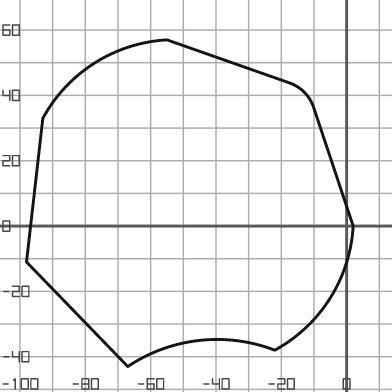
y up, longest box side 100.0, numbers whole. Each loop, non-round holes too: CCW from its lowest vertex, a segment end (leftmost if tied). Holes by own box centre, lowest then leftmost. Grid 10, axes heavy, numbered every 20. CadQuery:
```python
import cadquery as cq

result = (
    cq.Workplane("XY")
    .moveTo(-67.0, -43.0)
    .threePointArc((-45.0, -35.0), (-22.0, -38.0))
    .threePointArc((-5.0, -22.0), (2.0, 0.0))
    .lineTo(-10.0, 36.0)
    .threePointArc((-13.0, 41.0), (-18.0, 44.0))
    .lineTo(-55.0, 57.0)
    .threePointArc((-77.0, 50.0), (-93.0, 33.0))
    .lineTo(-98.0, -11.0)
    .close()
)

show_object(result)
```